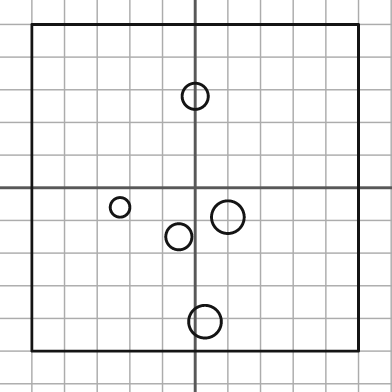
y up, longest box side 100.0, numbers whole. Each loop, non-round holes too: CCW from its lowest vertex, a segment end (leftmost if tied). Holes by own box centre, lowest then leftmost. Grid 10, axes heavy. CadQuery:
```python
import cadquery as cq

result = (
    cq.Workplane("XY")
    .moveTo(-50.0, -50.0)
    .lineTo(50.0, -50.0)
    .lineTo(50.0, 50.0)
    .lineTo(-50.0, 50.0)
    .close()
    .moveTo(3.0, -41.0)
    .circle(5.0)
    .moveTo(-5.0, -15.0)
    .circle(4.0)
    .moveTo(10.0, -9.0)
    .circle(5.0)
    .moveTo(-23.0, -6.0)
    .circle(3.0)
    .moveTo(0.0, 28.0)
    .circle(4.0)
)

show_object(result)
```